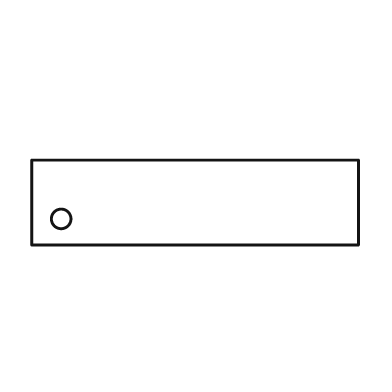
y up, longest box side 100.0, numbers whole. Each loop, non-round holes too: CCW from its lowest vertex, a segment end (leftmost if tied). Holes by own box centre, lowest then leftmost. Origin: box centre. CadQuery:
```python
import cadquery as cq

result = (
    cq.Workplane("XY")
    .moveTo(-50.0, -13.0)
    .lineTo(50.0, -13.0)
    .lineTo(50.0, 13.0)
    .lineTo(-50.0, 13.0)
    .close()
    .moveTo(-41.0, -5.0)
    .circle(3.0)
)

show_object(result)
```